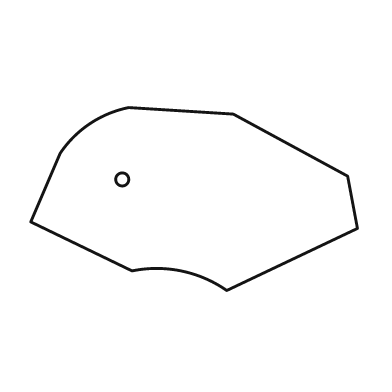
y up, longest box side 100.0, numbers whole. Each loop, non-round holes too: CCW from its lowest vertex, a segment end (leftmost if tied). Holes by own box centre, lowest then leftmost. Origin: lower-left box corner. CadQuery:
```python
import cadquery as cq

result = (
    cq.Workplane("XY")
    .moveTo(60.0, 0.0)
    .lineTo(100.0, 19.0)
    .lineTo(97.0, 35.0)
    .lineTo(62.0, 54.0)
    .lineTo(30.0, 56.0)
    .threePointArc((18.0, 51.0), (9.0, 42.0))
    .lineTo(0.0, 21.0)
    .lineTo(31.0, 6.0)
    .threePointArc((46.0, 6.0), (60.0, 0.0))
    .close()
    .moveTo(28.0, 34.0)
    .circle(2.0)
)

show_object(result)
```